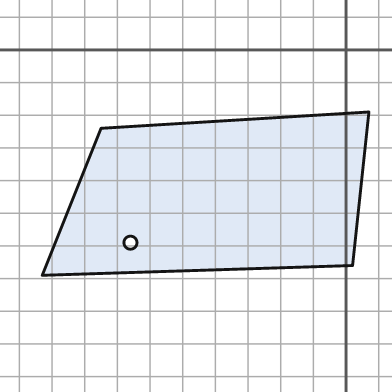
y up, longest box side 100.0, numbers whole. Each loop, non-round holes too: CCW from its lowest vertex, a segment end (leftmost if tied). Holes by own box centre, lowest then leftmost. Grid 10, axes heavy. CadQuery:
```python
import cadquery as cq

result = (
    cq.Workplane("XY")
    .moveTo(-93.0, -69.0)
    .lineTo(2.0, -66.0)
    .lineTo(7.0, -19.0)
    .lineTo(-75.0, -24.0)
    .close()
    .moveTo(-66.0, -59.0)
    .circle(2.0)
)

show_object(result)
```